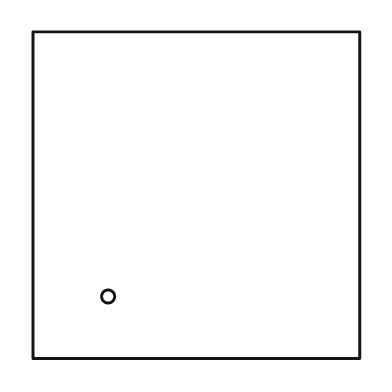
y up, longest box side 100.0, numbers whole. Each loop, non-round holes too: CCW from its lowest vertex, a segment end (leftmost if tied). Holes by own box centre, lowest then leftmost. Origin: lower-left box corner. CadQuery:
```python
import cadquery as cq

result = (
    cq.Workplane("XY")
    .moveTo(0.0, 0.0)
    .lineTo(100.0, 0.0)
    .lineTo(100.0, 100.0)
    .lineTo(0.0, 100.0)
    .close()
    .moveTo(23.0, 19.0)
    .circle(2.0)
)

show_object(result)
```